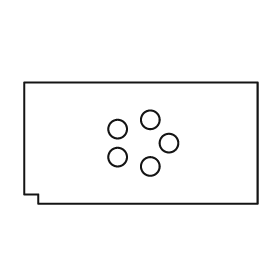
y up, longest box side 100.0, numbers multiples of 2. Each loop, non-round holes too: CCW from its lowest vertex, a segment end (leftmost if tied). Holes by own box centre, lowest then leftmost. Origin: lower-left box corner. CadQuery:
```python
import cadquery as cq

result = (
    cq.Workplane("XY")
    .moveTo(6.0, 0.0)
    .lineTo(100.0, 0.0)
    .lineTo(100.0, 52.0)
    .lineTo(0.0, 52.0)
    .lineTo(0.0, 4.0)
    .lineTo(6.0, 4.0)
    .close()
    .moveTo(54.0, 16.0)
    .circle(4.0)
    .moveTo(40.0, 20.0)
    .circle(4.0)
    .moveTo(62.0, 26.0)
    .circle(4.0)
    .moveTo(40.0, 32.0)
    .circle(4.0)
    .moveTo(54.0, 36.0)
    .circle(4.0)
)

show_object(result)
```